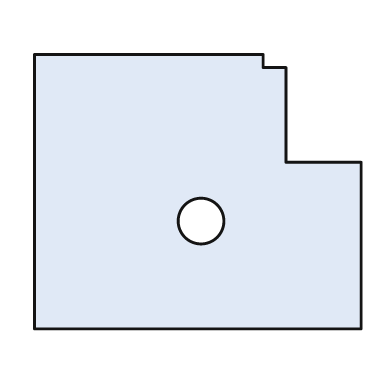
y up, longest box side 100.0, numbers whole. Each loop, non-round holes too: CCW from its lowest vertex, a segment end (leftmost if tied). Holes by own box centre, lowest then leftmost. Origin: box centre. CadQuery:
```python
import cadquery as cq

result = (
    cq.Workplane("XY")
    .moveTo(-50.0, -42.0)
    .lineTo(50.0, -42.0)
    .lineTo(50.0, 9.0)
    .lineTo(27.0, 9.0)
    .lineTo(27.0, 38.0)
    .lineTo(20.0, 38.0)
    .lineTo(20.0, 42.0)
    .lineTo(-50.0, 42.0)
    .close()
    .moveTo(1.0, -9.0)
    .circle(7.0)
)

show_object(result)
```